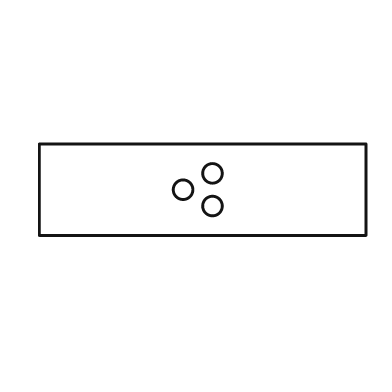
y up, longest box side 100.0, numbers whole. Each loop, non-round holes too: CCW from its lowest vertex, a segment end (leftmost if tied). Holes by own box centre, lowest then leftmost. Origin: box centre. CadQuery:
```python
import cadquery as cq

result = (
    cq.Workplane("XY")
    .moveTo(-50.0, -14.0)
    .lineTo(50.0, -14.0)
    .lineTo(50.0, 14.0)
    .lineTo(-50.0, 14.0)
    .close()
    .moveTo(3.0, -5.0)
    .circle(3.0)
    .moveTo(-6.0, 0.0)
    .circle(3.0)
    .moveTo(3.0, 5.0)
    .circle(3.0)
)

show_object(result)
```